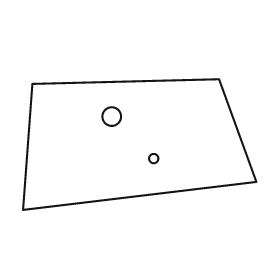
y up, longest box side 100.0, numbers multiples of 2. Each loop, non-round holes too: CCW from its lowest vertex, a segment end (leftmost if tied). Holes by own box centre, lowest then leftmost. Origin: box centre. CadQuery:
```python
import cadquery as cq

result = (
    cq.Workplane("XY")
    .moveTo(-50.0, -28.0)
    .lineTo(50.0, -16.0)
    .lineTo(34.0, 28.0)
    .lineTo(-46.0, 26.0)
    .close()
    .moveTo(6.0, -6.0)
    .circle(2.0)
    .moveTo(-12.0, 12.0)
    .circle(4.0)
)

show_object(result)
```